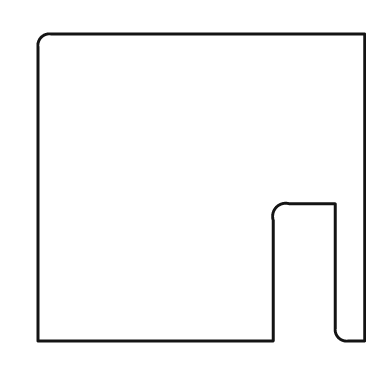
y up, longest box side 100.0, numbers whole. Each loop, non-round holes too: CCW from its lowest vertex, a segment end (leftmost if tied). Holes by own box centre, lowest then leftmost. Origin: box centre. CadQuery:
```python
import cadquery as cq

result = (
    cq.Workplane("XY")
    .moveTo(-50.0, -47.0)
    .lineTo(22.0, -47.0)
    .lineTo(22.0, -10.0)
    .threePointArc((23.0, -6.0), (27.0, -5.0))
    .lineTo(41.0, -5.0)
    .lineTo(41.0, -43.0)
    .threePointArc((42.0, -46.0), (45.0, -47.0))
    .lineTo(50.0, -47.0)
    .lineTo(50.0, 47.0)
    .lineTo(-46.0, 47.0)
    .threePointArc((-49.0, 46.0), (-50.0, 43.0))
    .close()
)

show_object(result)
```